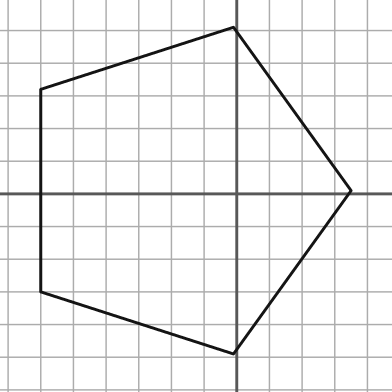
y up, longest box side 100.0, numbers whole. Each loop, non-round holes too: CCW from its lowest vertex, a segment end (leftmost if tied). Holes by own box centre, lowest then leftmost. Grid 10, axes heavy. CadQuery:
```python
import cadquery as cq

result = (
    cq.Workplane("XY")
    .moveTo(-1.0, -49.0)
    .lineTo(35.0, 1.0)
    .lineTo(-1.0, 51.0)
    .lineTo(-60.0, 32.0)
    .lineTo(-60.0, -30.0)
    .close()
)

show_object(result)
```